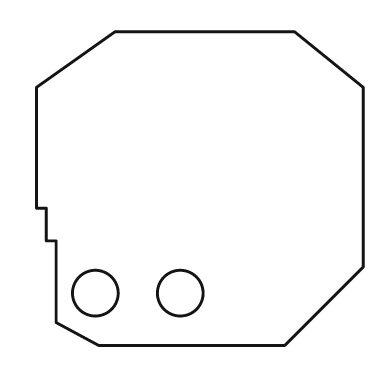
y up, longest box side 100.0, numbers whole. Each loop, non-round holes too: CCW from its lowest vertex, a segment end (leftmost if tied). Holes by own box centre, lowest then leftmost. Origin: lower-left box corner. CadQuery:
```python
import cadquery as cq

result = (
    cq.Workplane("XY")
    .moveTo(19.0, 0.0)
    .lineTo(76.0, 0.0)
    .lineTo(100.0, 24.0)
    .lineTo(100.0, 79.0)
    .lineTo(79.0, 96.0)
    .lineTo(24.0, 96.0)
    .lineTo(0.0, 79.0)
    .lineTo(0.0, 42.0)
    .lineTo(3.0, 42.0)
    .lineTo(3.0, 32.0)
    .lineTo(6.0, 32.0)
    .lineTo(6.0, 7.0)
    .close()
    .moveTo(18.0, 16.0)
    .circle(7.0)
    .moveTo(44.0, 16.0)
    .circle(7.0)
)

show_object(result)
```